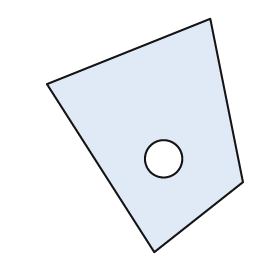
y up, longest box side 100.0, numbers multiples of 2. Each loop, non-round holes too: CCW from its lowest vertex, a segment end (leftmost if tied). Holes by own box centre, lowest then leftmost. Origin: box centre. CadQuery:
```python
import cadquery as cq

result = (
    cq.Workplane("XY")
    .moveTo(4.0, -50.0)
    .lineTo(42.0, -20.0)
    .lineTo(28.0, 50.0)
    .lineTo(-42.0, 22.0)
    .close()
    .moveTo(8.0, -10.0)
    .circle(8.0)
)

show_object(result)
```